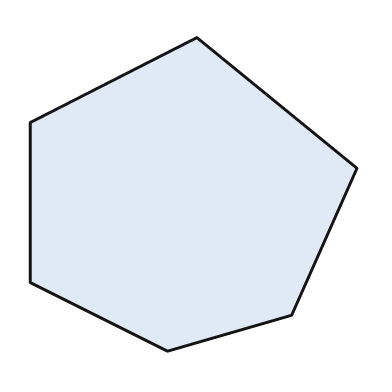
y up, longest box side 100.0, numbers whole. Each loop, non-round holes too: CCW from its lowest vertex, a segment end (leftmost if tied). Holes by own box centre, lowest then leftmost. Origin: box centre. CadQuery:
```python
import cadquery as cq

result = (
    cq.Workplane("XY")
    .moveTo(-8.0, -48.0)
    .lineTo(30.0, -37.0)
    .lineTo(50.0, 8.0)
    .lineTo(1.0, 48.0)
    .lineTo(-50.0, 22.0)
    .lineTo(-50.0, -27.0)
    .close()
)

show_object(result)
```